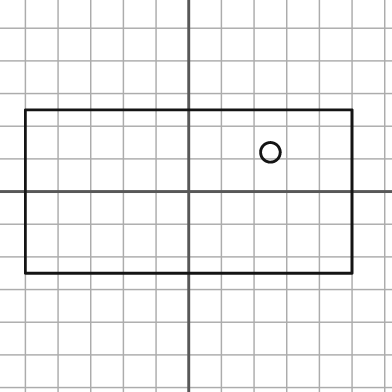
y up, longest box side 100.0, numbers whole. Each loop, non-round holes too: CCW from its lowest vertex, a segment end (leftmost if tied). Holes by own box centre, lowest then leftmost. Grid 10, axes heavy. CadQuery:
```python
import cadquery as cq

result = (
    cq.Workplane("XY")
    .moveTo(-50.0, -25.0)
    .lineTo(50.0, -25.0)
    .lineTo(50.0, 25.0)
    .lineTo(-50.0, 25.0)
    .close()
    .moveTo(25.0, 12.0)
    .circle(3.0)
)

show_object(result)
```